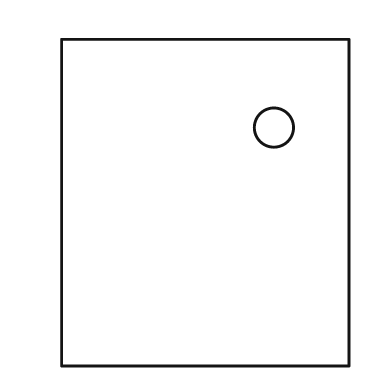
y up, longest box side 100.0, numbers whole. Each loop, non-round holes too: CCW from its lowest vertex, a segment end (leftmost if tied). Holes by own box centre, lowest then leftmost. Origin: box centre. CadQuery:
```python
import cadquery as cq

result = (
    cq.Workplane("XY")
    .moveTo(-44.0, -50.0)
    .lineTo(44.0, -50.0)
    .lineTo(44.0, 50.0)
    .lineTo(-44.0, 50.0)
    .close()
    .moveTo(21.0, 23.0)
    .circle(6.0)
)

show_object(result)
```